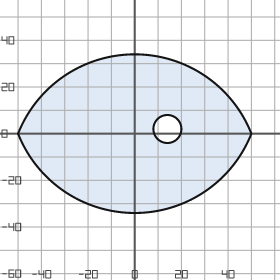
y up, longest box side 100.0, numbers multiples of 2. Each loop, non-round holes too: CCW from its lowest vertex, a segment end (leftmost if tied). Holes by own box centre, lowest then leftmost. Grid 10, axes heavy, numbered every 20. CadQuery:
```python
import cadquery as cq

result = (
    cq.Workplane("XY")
    .moveTo(-50.0, 0.0)
    .threePointArc((0.0, -34.0), (50.0, 0.0))
    .threePointArc((0.0, 34.0), (-50.0, 0.0))
    .close()
    .moveTo(14.0, 2.0)
    .circle(6.0)
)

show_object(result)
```